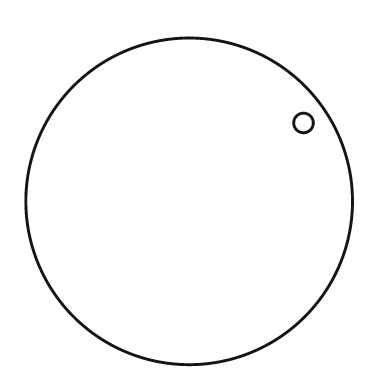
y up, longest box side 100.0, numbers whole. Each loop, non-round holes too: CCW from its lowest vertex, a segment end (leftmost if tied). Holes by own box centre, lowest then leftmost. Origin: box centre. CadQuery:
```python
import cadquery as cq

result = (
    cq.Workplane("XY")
    .moveTo(0.0, 0.0)
    .circle(50.0)
    .moveTo(35.0, 24.0)
    .circle(3.0)
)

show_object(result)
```